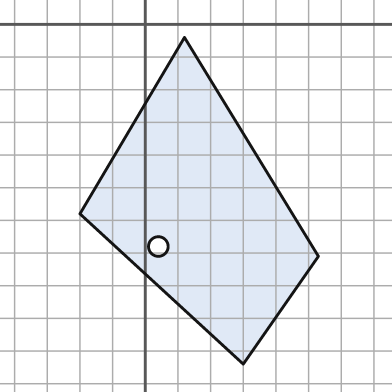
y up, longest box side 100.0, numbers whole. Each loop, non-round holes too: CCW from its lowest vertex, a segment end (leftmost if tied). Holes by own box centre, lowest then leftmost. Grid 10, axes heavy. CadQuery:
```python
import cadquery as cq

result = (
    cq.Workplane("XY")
    .moveTo(30.0, -104.0)
    .lineTo(53.0, -71.0)
    .lineTo(12.0, -4.0)
    .lineTo(-20.0, -58.0)
    .close()
    .moveTo(4.0, -68.0)
    .circle(3.0)
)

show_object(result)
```